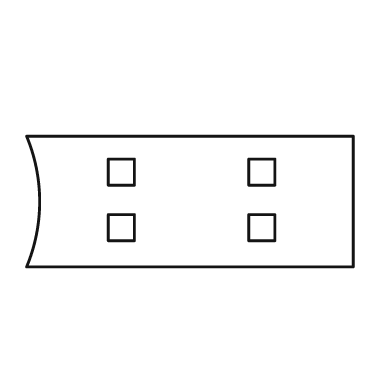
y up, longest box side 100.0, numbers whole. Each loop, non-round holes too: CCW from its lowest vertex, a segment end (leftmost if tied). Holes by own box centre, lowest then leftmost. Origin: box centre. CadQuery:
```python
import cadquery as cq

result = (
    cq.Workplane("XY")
    .moveTo(-50.0, -20.0)
    .lineTo(50.0, -20.0)
    .lineTo(50.0, 20.0)
    .lineTo(-50.0, 20.0)
    .threePointArc((-46.0, 0.0), (-50.0, -20.0))
    .close()
    .moveTo(-25.0, -12.0)
    .lineTo(-17.0, -12.0)
    .lineTo(-17.0, -4.0)
    .lineTo(-25.0, -4.0)
    .close()
    .moveTo(18.0, -12.0)
    .lineTo(26.0, -12.0)
    .lineTo(26.0, -4.0)
    .lineTo(18.0, -4.0)
    .close()
    .moveTo(-25.0, 5.0)
    .lineTo(-17.0, 5.0)
    .lineTo(-17.0, 13.0)
    .lineTo(-25.0, 13.0)
    .close()
    .moveTo(18.0, 5.0)
    .lineTo(26.0, 5.0)
    .lineTo(26.0, 13.0)
    .lineTo(18.0, 13.0)
    .close()
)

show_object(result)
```